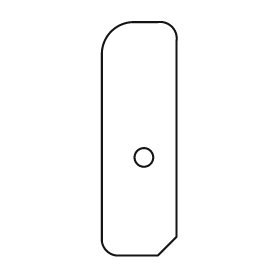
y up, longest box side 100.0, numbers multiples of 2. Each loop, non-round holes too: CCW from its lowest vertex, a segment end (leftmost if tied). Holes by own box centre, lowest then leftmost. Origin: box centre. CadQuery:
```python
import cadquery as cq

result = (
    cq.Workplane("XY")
    .moveTo(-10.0, -50.0)
    .lineTo(8.0, -50.0)
    .lineTo(16.0, -42.0)
    .lineTo(16.0, 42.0)
    .threePointArc((14.0, 48.0), (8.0, 50.0))
    .lineTo(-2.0, 50.0)
    .threePointArc((-12.0, 46.0), (-16.0, 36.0))
    .lineTo(-16.0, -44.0)
    .threePointArc((-14.0, -48.0), (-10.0, -50.0))
    .close()
    .moveTo(2.0, -8.0)
    .circle(4.0)
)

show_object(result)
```